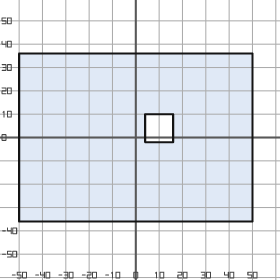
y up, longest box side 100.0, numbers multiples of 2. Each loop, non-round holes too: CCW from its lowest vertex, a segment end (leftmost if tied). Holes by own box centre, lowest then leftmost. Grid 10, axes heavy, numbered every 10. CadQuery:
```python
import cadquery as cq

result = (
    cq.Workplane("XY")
    .moveTo(-50.0, -36.0)
    .lineTo(50.0, -36.0)
    .lineTo(50.0, 36.0)
    .lineTo(-50.0, 36.0)
    .close()
    .moveTo(4.0, -2.0)
    .lineTo(16.0, -2.0)
    .lineTo(16.0, 10.0)
    .lineTo(4.0, 10.0)
    .close()
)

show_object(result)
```